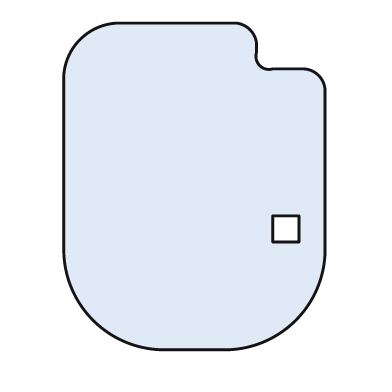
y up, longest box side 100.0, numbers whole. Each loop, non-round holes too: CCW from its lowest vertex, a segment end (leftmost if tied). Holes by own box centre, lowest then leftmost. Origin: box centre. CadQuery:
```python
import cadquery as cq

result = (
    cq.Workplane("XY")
    .moveTo(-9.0, -50.0)
    .lineTo(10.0, -50.0)
    .threePointArc((31.0, -41.0), (40.0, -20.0))
    .lineTo(40.0, 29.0)
    .threePointArc((38.0, 34.0), (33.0, 36.0))
    .lineTo(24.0, 36.0)
    .threePointArc((20.0, 37.0), (19.0, 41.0))
    .lineTo(19.0, 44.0)
    .threePointArc((17.0, 48.0), (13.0, 50.0))
    .lineTo(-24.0, 50.0)
    .threePointArc((-35.0, 45.0), (-40.0, 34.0))
    .lineTo(-40.0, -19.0)
    .threePointArc((-31.0, -41.0), (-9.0, -50.0))
    .close()
    .moveTo(24.0, -17.0)
    .lineTo(32.0, -17.0)
    .lineTo(32.0, -9.0)
    .lineTo(24.0, -9.0)
    .close()
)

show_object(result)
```